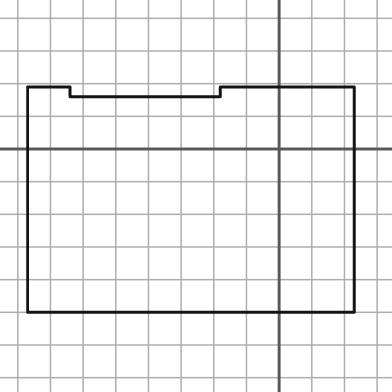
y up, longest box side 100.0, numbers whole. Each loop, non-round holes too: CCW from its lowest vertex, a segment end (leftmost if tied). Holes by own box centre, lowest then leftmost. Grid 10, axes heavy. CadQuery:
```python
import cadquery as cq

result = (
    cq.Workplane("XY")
    .moveTo(-77.0, -50.0)
    .lineTo(23.0, -50.0)
    .lineTo(23.0, 19.0)
    .lineTo(-18.0, 19.0)
    .lineTo(-18.0, 16.0)
    .lineTo(-64.0, 16.0)
    .lineTo(-64.0, 19.0)
    .lineTo(-77.0, 19.0)
    .close()
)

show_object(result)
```